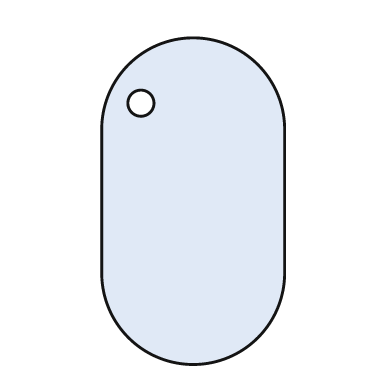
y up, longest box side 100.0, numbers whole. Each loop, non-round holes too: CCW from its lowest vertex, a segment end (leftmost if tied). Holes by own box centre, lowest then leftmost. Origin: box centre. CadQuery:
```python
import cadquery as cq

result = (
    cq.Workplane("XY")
    .moveTo(-28.0, -22.0)
    .threePointArc((0.0, -50.0), (28.0, -22.0))
    .lineTo(28.0, 22.0)
    .threePointArc((0.0, 50.0), (-28.0, 22.0))
    .close()
    .moveTo(-16.0, 30.0)
    .circle(4.0)
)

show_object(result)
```